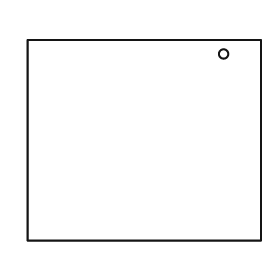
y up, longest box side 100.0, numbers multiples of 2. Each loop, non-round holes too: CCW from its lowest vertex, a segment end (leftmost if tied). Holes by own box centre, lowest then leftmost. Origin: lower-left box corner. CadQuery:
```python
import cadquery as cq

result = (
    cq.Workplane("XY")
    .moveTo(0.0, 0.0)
    .lineTo(100.0, 0.0)
    .lineTo(100.0, 86.0)
    .lineTo(0.0, 86.0)
    .close()
    .moveTo(84.0, 80.0)
    .circle(2.0)
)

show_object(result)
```